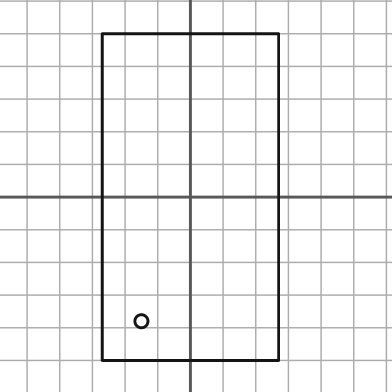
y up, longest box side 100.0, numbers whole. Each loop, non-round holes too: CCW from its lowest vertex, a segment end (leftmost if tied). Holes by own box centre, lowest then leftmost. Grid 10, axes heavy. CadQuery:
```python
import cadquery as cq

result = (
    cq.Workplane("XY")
    .moveTo(-27.0, -50.0)
    .lineTo(27.0, -50.0)
    .lineTo(27.0, 50.0)
    .lineTo(-27.0, 50.0)
    .close()
    .moveTo(-15.0, -38.0)
    .circle(2.0)
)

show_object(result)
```